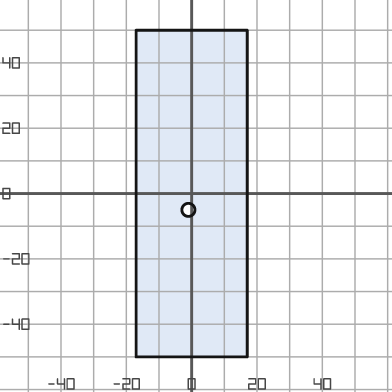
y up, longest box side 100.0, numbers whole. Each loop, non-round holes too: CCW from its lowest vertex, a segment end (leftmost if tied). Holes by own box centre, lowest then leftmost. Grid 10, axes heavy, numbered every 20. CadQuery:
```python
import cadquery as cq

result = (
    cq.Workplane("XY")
    .moveTo(-17.0, -50.0)
    .lineTo(17.0, -50.0)
    .lineTo(17.0, 50.0)
    .lineTo(-17.0, 50.0)
    .close()
    .moveTo(-1.0, -5.0)
    .circle(2.0)
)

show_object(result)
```